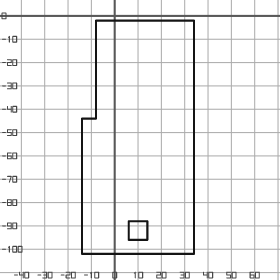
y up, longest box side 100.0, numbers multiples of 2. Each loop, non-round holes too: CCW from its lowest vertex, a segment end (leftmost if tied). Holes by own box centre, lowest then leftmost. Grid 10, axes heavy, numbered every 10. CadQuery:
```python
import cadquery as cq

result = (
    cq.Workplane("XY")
    .moveTo(-14.0, -102.0)
    .lineTo(34.0, -102.0)
    .lineTo(34.0, -2.0)
    .lineTo(-8.0, -2.0)
    .lineTo(-8.0, -44.0)
    .lineTo(-14.0, -44.0)
    .close()
    .moveTo(6.0, -96.0)
    .lineTo(14.0, -96.0)
    .lineTo(14.0, -88.0)
    .lineTo(6.0, -88.0)
    .close()
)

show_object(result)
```